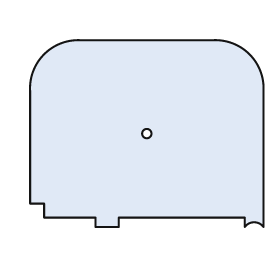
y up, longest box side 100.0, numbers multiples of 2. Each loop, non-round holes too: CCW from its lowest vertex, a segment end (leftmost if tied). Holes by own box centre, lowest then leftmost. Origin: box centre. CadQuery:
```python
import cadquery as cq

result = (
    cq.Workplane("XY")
    .moveTo(-22.0, -40.0)
    .lineTo(-12.0, -40.0)
    .lineTo(-12.0, -36.0)
    .lineTo(42.0, -36.0)
    .lineTo(42.0, -40.0)
    .threePointArc((46.0, -38.0), (50.0, -40.0))
    .lineTo(50.0, 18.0)
    .threePointArc((44.0, 34.0), (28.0, 40.0))
    .lineTo(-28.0, 40.0)
    .threePointArc((-44.0, 34.0), (-50.0, 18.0))
    .lineTo(-50.0, -30.0)
    .lineTo(-44.0, -30.0)
    .lineTo(-44.0, -36.0)
    .lineTo(-22.0, -36.0)
    .close()
    .moveTo(0.0, 0.0)
    .circle(2.0)
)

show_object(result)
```